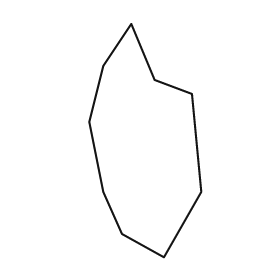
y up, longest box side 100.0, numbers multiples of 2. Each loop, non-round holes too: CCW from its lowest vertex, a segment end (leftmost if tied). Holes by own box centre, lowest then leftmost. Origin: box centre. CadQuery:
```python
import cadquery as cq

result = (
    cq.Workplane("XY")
    .moveTo(8.0, -50.0)
    .lineTo(24.0, -22.0)
    .lineTo(20.0, 20.0)
    .lineTo(4.0, 26.0)
    .lineTo(-6.0, 50.0)
    .lineTo(-18.0, 32.0)
    .lineTo(-24.0, 8.0)
    .lineTo(-18.0, -22.0)
    .lineTo(-10.0, -40.0)
    .close()
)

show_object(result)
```